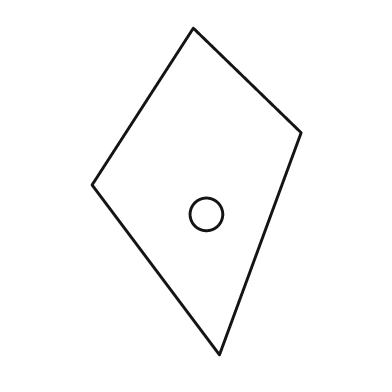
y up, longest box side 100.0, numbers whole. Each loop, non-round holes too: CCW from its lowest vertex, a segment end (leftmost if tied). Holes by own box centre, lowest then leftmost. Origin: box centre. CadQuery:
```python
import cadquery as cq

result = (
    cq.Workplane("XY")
    .moveTo(7.0, -50.0)
    .lineTo(32.0, 18.0)
    .lineTo(-1.0, 50.0)
    .lineTo(-32.0, 2.0)
    .close()
    .moveTo(3.0, -7.0)
    .circle(5.0)
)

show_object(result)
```